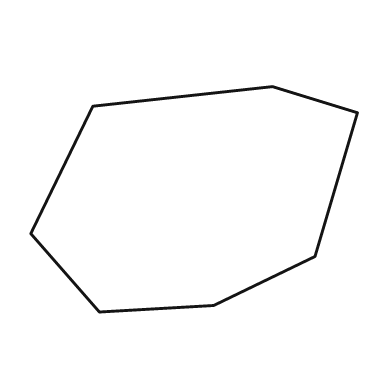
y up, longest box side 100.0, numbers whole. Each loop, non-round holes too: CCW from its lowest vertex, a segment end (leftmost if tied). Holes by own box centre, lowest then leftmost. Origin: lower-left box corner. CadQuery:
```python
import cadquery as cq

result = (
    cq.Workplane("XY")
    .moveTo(21.0, 0.0)
    .lineTo(56.0, 2.0)
    .lineTo(87.0, 17.0)
    .lineTo(100.0, 61.0)
    .lineTo(74.0, 69.0)
    .lineTo(19.0, 63.0)
    .lineTo(0.0, 24.0)
    .close()
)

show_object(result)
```